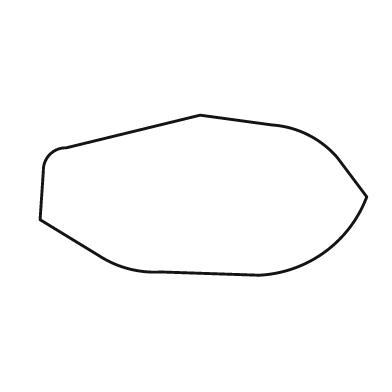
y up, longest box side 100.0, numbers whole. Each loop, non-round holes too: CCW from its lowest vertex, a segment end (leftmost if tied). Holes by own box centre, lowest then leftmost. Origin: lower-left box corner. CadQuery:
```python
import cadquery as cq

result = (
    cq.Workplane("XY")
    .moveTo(67.0, 0.0)
    .threePointArc((87.0, 7.0), (100.0, 24.0))
    .lineTo(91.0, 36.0)
    .threePointArc((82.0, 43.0), (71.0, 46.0))
    .lineTo(49.0, 49.0)
    .lineTo(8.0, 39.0)
    .threePointArc((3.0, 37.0), (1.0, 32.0))
    .lineTo(0.0, 17.0)
    .lineTo(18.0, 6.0)
    .threePointArc((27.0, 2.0), (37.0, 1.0))
    .close()
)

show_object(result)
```